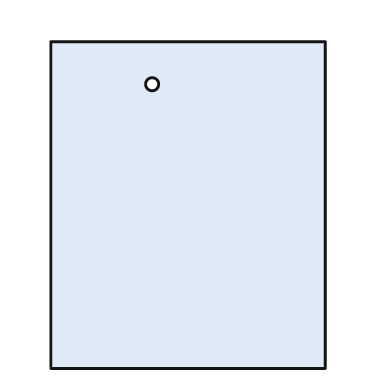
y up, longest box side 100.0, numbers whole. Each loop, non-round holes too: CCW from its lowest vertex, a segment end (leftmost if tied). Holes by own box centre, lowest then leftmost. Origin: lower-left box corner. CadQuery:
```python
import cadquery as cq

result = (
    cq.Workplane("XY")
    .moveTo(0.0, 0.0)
    .lineTo(84.0, 0.0)
    .lineTo(84.0, 100.0)
    .lineTo(0.0, 100.0)
    .close()
    .moveTo(31.0, 87.0)
    .circle(2.0)
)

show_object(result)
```